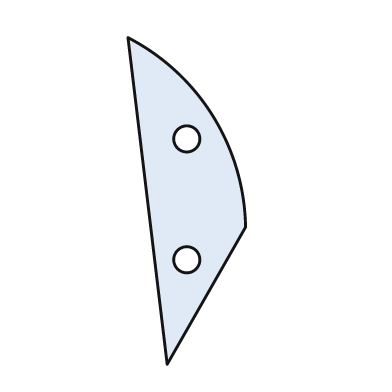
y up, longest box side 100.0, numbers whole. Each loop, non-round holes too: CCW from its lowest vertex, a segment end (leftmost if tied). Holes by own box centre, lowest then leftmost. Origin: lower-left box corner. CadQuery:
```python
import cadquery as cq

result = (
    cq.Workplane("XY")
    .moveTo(12.0, 0.0)
    .lineTo(36.0, 42.0)
    .threePointArc((26.0, 76.0), (0.0, 100.0))
    .close()
    .moveTo(18.0, 32.0)
    .circle(4.0)
    .moveTo(18.0, 69.0)
    .circle(4.0)
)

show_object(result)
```